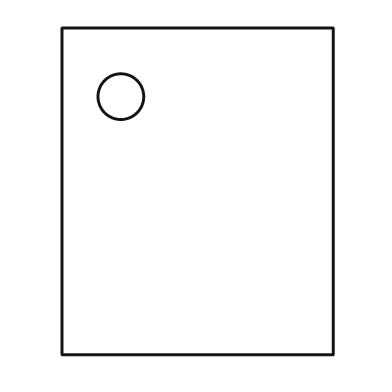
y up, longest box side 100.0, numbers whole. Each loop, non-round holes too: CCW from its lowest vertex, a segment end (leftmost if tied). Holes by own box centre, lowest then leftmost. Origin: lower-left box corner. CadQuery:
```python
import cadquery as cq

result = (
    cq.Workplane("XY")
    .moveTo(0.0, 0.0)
    .lineTo(83.0, 0.0)
    .lineTo(83.0, 100.0)
    .lineTo(0.0, 100.0)
    .close()
    .moveTo(18.0, 79.0)
    .circle(7.0)
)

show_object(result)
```